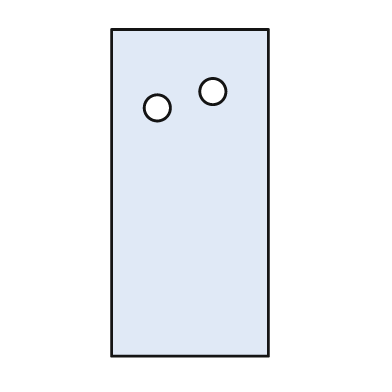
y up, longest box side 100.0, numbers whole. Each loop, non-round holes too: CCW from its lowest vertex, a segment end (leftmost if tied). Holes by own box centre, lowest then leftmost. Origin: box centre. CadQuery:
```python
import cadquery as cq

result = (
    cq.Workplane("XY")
    .moveTo(-24.0, -50.0)
    .lineTo(24.0, -50.0)
    .lineTo(24.0, 50.0)
    .lineTo(-24.0, 50.0)
    .close()
    .moveTo(-10.0, 26.0)
    .circle(4.0)
    .moveTo(7.0, 31.0)
    .circle(4.0)
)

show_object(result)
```